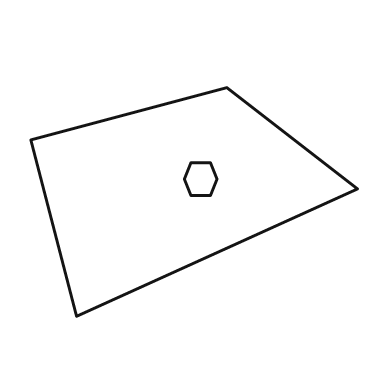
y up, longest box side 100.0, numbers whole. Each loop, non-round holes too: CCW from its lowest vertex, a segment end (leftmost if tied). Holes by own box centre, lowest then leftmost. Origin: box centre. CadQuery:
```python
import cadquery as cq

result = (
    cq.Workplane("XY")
    .moveTo(-36.0, -35.0)
    .lineTo(50.0, 4.0)
    .lineTo(10.0, 35.0)
    .lineTo(-50.0, 19.0)
    .close()
    .moveTo(-1.0, 2.0)
    .lineTo(5.0, 2.0)
    .lineTo(7.0, 7.0)
    .lineTo(5.0, 12.0)
    .lineTo(-1.0, 12.0)
    .lineTo(-3.0, 7.0)
    .close()
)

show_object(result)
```